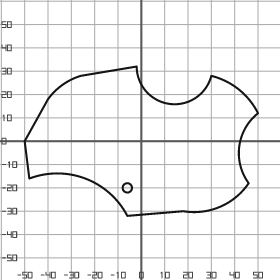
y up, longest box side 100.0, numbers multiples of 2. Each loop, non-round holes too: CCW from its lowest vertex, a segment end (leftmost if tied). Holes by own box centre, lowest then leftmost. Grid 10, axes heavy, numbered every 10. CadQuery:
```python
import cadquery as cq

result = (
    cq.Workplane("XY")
    .moveTo(-6.0, -32.0)
    .lineTo(18.0, -30.0)
    .threePointArc((34.0, -28.0), (46.0, -18.0))
    .threePointArc((42.0, -2.0), (50.0, 12.0))
    .threePointArc((42.0, 22.0), (30.0, 28.0))
    .threePointArc((12.0, 16.0), (-2.0, 32.0))
    .lineTo(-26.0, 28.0)
    .threePointArc((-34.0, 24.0), (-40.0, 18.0))
    .lineTo(-50.0, 0.0)
    .lineTo(-48.0, -16.0)
    .threePointArc((-24.0, -16.0), (-6.0, -32.0))
    .close()
    .moveTo(-6.0, -20.0)
    .circle(2.0)
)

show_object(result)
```